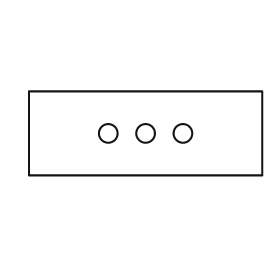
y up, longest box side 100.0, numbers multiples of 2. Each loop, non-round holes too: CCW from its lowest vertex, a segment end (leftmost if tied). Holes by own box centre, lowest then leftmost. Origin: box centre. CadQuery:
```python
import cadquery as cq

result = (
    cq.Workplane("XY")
    .moveTo(-50.0, -18.0)
    .lineTo(50.0, -18.0)
    .lineTo(50.0, 18.0)
    .lineTo(-50.0, 18.0)
    .close()
    .moveTo(-16.0, 0.0)
    .circle(4.0)
    .moveTo(0.0, 0.0)
    .circle(4.0)
    .moveTo(16.0, 0.0)
    .circle(4.0)
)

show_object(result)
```